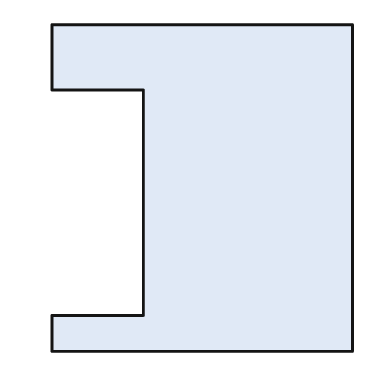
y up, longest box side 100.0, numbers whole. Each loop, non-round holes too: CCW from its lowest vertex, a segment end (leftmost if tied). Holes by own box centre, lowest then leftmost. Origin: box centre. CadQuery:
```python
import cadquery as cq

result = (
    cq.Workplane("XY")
    .moveTo(-46.0, -50.0)
    .lineTo(46.0, -50.0)
    .lineTo(46.0, 50.0)
    .lineTo(-46.0, 50.0)
    .lineTo(-46.0, 30.0)
    .lineTo(-18.0, 30.0)
    .lineTo(-18.0, -39.0)
    .lineTo(-46.0, -39.0)
    .close()
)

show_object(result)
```